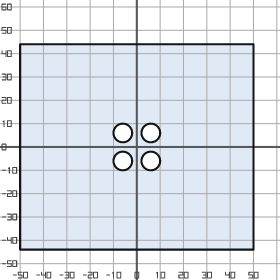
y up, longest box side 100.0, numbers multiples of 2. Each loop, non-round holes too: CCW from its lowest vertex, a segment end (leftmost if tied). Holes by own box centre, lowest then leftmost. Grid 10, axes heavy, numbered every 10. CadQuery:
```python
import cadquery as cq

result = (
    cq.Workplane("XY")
    .moveTo(-50.0, -44.0)
    .lineTo(50.0, -44.0)
    .lineTo(50.0, 44.0)
    .lineTo(-50.0, 44.0)
    .close()
    .moveTo(-6.0, -6.0)
    .circle(4.0)
    .moveTo(6.0, -6.0)
    .circle(4.0)
    .moveTo(-6.0, 6.0)
    .circle(4.0)
    .moveTo(6.0, 6.0)
    .circle(4.0)
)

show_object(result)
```